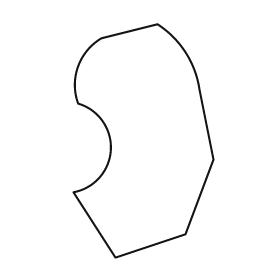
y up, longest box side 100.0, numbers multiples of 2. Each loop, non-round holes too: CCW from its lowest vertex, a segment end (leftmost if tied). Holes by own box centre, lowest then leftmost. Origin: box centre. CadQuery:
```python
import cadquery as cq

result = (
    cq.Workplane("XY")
    .moveTo(-12.0, -50.0)
    .lineTo(18.0, -40.0)
    .lineTo(30.0, -8.0)
    .lineTo(24.0, 22.0)
    .threePointArc((18.0, 38.0), (6.0, 50.0))
    .lineTo(-18.0, 44.0)
    .threePointArc((-28.0, 32.0), (-28.0, 16.0))
    .threePointArc((-14.0, -4.0), (-30.0, -22.0))
    .close()
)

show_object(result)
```